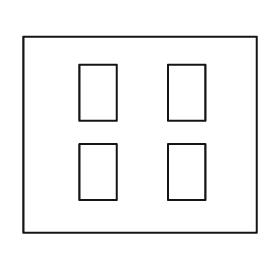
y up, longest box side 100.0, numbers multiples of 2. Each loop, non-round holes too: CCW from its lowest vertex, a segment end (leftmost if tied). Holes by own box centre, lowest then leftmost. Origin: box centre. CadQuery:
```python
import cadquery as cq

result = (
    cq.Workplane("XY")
    .moveTo(-50.0, -42.0)
    .lineTo(50.0, -42.0)
    .lineTo(50.0, 42.0)
    .lineTo(-50.0, 42.0)
    .close()
    .moveTo(-26.0, -28.0)
    .lineTo(-10.0, -28.0)
    .lineTo(-10.0, -4.0)
    .lineTo(-26.0, -4.0)
    .close()
    .moveTo(12.0, -28.0)
    .lineTo(28.0, -28.0)
    .lineTo(28.0, -4.0)
    .lineTo(12.0, -4.0)
    .close()
    .moveTo(-26.0, 6.0)
    .lineTo(-10.0, 6.0)
    .lineTo(-10.0, 30.0)
    .lineTo(-26.0, 30.0)
    .close()
    .moveTo(12.0, 6.0)
    .lineTo(28.0, 6.0)
    .lineTo(28.0, 30.0)
    .lineTo(12.0, 30.0)
    .close()
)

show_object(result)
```